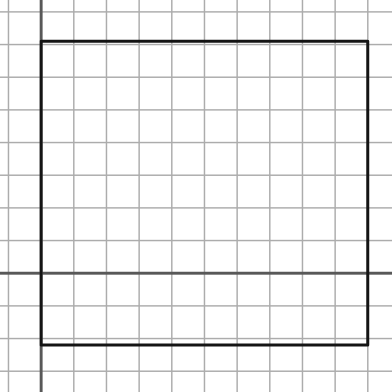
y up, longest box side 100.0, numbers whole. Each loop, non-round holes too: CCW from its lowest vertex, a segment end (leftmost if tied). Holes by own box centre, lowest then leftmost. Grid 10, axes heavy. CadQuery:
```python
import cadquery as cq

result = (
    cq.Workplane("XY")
    .moveTo(0.0, -22.0)
    .lineTo(100.0, -22.0)
    .lineTo(100.0, 71.0)
    .lineTo(0.0, 71.0)
    .close()
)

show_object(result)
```